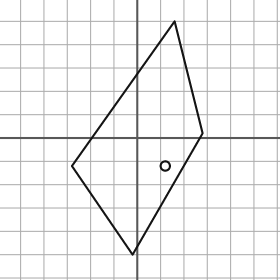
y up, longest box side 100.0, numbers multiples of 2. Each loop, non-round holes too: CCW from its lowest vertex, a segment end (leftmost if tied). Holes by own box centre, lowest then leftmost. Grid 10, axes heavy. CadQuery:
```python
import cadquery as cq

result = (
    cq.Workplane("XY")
    .moveTo(-2.0, -50.0)
    .lineTo(28.0, 2.0)
    .lineTo(16.0, 50.0)
    .lineTo(-28.0, -12.0)
    .close()
    .moveTo(12.0, -12.0)
    .circle(2.0)
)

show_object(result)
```